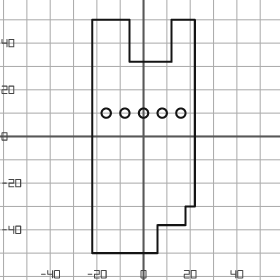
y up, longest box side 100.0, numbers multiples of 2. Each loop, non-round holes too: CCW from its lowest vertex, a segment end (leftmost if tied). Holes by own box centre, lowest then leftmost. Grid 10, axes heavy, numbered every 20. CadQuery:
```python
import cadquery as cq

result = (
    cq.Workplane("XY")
    .moveTo(-22.0, -50.0)
    .lineTo(6.0, -50.0)
    .lineTo(6.0, -38.0)
    .lineTo(18.0, -38.0)
    .lineTo(18.0, -30.0)
    .lineTo(22.0, -30.0)
    .lineTo(22.0, 50.0)
    .lineTo(12.0, 50.0)
    .lineTo(12.0, 32.0)
    .lineTo(-6.0, 32.0)
    .lineTo(-6.0, 50.0)
    .lineTo(-22.0, 50.0)
    .close()
    .moveTo(-16.0, 10.0)
    .circle(2.0)
    .moveTo(-8.0, 10.0)
    .circle(2.0)
    .moveTo(0.0, 10.0)
    .circle(2.0)
    .moveTo(8.0, 10.0)
    .circle(2.0)
    .moveTo(16.0, 10.0)
    .circle(2.0)
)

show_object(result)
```